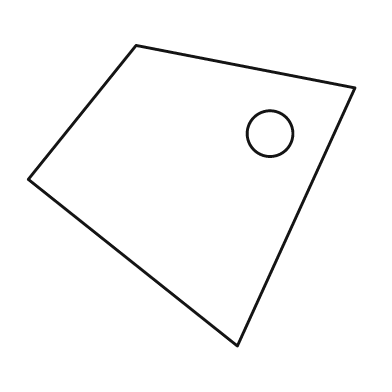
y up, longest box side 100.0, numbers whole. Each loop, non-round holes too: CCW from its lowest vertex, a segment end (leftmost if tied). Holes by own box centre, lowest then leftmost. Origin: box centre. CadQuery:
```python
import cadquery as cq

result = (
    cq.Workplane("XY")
    .moveTo(14.0, -46.0)
    .lineTo(50.0, 33.0)
    .lineTo(-17.0, 46.0)
    .lineTo(-50.0, 5.0)
    .close()
    .moveTo(24.0, 19.0)
    .circle(7.0)
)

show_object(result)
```